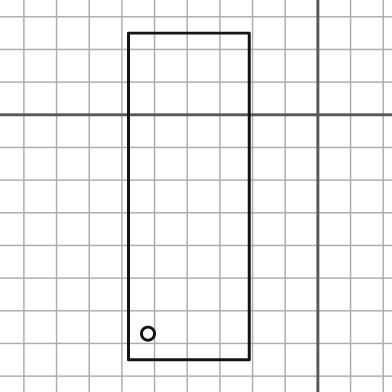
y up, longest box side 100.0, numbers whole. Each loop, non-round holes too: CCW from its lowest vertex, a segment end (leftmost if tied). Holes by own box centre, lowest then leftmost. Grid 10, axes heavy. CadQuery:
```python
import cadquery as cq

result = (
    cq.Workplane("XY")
    .moveTo(-58.0, -75.0)
    .lineTo(-21.0, -75.0)
    .lineTo(-21.0, 25.0)
    .lineTo(-58.0, 25.0)
    .close()
    .moveTo(-52.0, -67.0)
    .circle(2.0)
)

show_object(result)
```